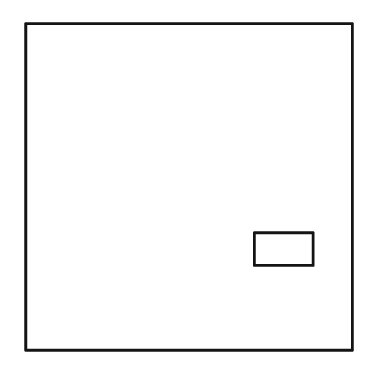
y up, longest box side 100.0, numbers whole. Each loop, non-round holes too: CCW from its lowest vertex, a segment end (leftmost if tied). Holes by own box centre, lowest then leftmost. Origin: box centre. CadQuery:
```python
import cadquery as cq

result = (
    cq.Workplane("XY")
    .moveTo(-50.0, -50.0)
    .lineTo(50.0, -50.0)
    .lineTo(50.0, 50.0)
    .lineTo(-50.0, 50.0)
    .close()
    .moveTo(20.0, -24.0)
    .lineTo(38.0, -24.0)
    .lineTo(38.0, -14.0)
    .lineTo(20.0, -14.0)
    .close()
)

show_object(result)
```